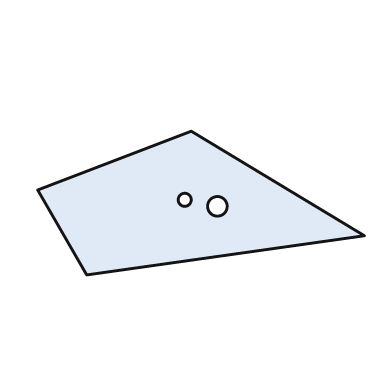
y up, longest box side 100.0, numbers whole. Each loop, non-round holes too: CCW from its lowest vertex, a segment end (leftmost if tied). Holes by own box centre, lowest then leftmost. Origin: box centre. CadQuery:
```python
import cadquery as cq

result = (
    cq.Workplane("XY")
    .moveTo(-35.0, -22.0)
    .lineTo(50.0, -10.0)
    .lineTo(-3.0, 22.0)
    .lineTo(-50.0, 4.0)
    .close()
    .moveTo(5.0, -1.0)
    .circle(3.0)
    .moveTo(-5.0, 1.0)
    .circle(2.0)
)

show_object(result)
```